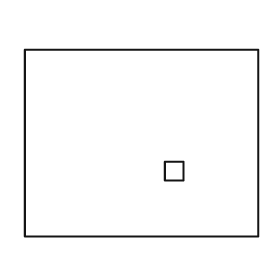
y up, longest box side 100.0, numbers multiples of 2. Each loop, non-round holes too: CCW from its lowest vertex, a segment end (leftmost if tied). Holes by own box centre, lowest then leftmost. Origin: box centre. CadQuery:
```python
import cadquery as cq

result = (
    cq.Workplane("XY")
    .moveTo(-50.0, -40.0)
    .lineTo(50.0, -40.0)
    .lineTo(50.0, 40.0)
    .lineTo(-50.0, 40.0)
    .close()
    .moveTo(10.0, -16.0)
    .lineTo(18.0, -16.0)
    .lineTo(18.0, -8.0)
    .lineTo(10.0, -8.0)
    .close()
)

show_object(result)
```